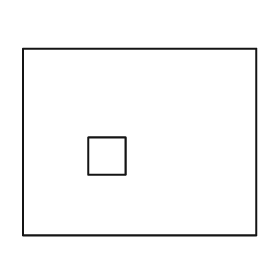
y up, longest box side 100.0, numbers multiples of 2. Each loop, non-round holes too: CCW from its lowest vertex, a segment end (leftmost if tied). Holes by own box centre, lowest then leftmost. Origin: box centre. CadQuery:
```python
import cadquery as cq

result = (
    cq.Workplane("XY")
    .moveTo(-50.0, -40.0)
    .lineTo(50.0, -40.0)
    .lineTo(50.0, 40.0)
    .lineTo(-50.0, 40.0)
    .close()
    .moveTo(-22.0, -14.0)
    .lineTo(-6.0, -14.0)
    .lineTo(-6.0, 2.0)
    .lineTo(-22.0, 2.0)
    .close()
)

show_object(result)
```